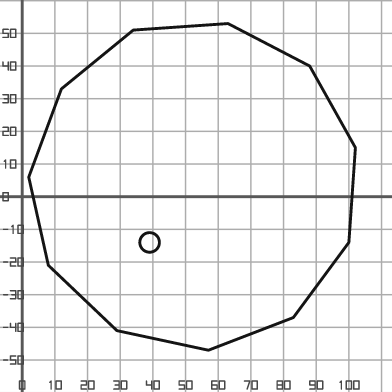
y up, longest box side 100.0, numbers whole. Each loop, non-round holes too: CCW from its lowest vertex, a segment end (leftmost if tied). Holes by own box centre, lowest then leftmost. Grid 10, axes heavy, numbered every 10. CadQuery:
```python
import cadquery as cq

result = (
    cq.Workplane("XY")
    .moveTo(57.0, -47.0)
    .lineTo(83.0, -37.0)
    .lineTo(100.0, -14.0)
    .lineTo(102.0, 15.0)
    .lineTo(88.0, 40.0)
    .lineTo(63.0, 53.0)
    .lineTo(34.0, 51.0)
    .lineTo(12.0, 33.0)
    .lineTo(2.0, 6.0)
    .lineTo(8.0, -21.0)
    .lineTo(29.0, -41.0)
    .close()
    .moveTo(39.0, -14.0)
    .circle(3.0)
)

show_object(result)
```